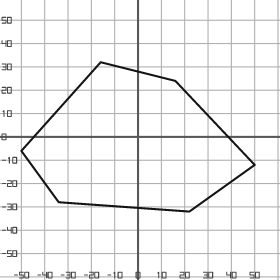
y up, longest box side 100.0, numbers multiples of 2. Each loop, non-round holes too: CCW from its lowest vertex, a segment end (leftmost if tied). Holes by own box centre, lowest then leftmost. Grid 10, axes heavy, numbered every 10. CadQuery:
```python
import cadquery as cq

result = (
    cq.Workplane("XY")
    .moveTo(22.0, -32.0)
    .lineTo(50.0, -12.0)
    .lineTo(16.0, 24.0)
    .lineTo(-16.0, 32.0)
    .lineTo(-50.0, -6.0)
    .lineTo(-34.0, -28.0)
    .close()
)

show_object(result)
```